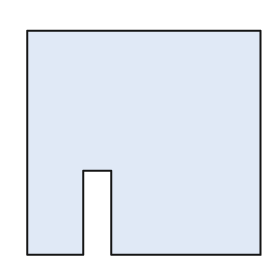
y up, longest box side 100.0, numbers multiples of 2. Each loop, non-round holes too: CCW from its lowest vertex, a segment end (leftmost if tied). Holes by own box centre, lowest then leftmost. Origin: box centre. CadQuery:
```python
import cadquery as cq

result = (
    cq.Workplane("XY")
    .moveTo(-50.0, -48.0)
    .lineTo(-26.0, -48.0)
    .lineTo(-26.0, -12.0)
    .lineTo(-14.0, -12.0)
    .lineTo(-14.0, -48.0)
    .lineTo(50.0, -48.0)
    .lineTo(50.0, 48.0)
    .lineTo(-50.0, 48.0)
    .close()
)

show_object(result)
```